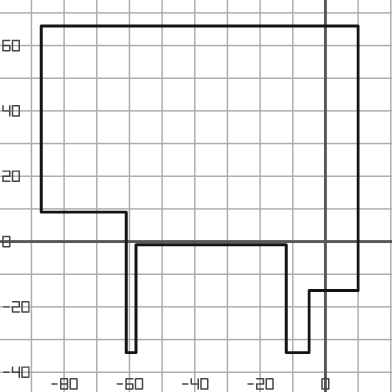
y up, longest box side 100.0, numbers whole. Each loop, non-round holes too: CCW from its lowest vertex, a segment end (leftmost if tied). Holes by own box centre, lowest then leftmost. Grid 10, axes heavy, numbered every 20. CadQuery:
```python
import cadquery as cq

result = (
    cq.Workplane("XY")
    .moveTo(-61.0, -34.0)
    .lineTo(-58.0, -34.0)
    .lineTo(-58.0, -1.0)
    .lineTo(-12.0, -1.0)
    .lineTo(-12.0, -34.0)
    .lineTo(-5.0, -34.0)
    .lineTo(-5.0, -15.0)
    .lineTo(10.0, -15.0)
    .lineTo(10.0, 66.0)
    .lineTo(-87.0, 66.0)
    .lineTo(-87.0, 9.0)
    .lineTo(-61.0, 9.0)
    .close()
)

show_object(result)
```